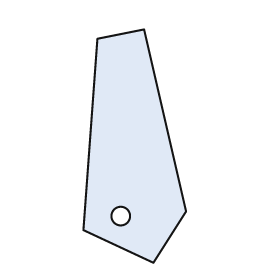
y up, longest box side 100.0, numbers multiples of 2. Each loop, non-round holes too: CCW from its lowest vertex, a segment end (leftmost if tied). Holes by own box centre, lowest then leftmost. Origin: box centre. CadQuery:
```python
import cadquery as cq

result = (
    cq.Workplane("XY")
    .moveTo(8.0, -50.0)
    .lineTo(22.0, -28.0)
    .lineTo(4.0, 50.0)
    .lineTo(-16.0, 46.0)
    .lineTo(-22.0, -36.0)
    .close()
    .moveTo(-6.0, -30.0)
    .circle(4.0)
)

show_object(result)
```